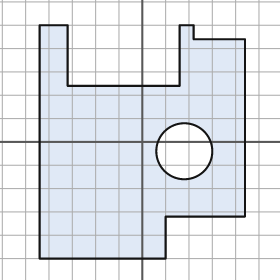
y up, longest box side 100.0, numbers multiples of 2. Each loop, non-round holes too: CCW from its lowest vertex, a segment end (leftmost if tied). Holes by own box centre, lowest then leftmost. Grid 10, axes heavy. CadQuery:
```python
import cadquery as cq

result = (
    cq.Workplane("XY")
    .moveTo(-44.0, -50.0)
    .lineTo(10.0, -50.0)
    .lineTo(10.0, -32.0)
    .lineTo(44.0, -32.0)
    .lineTo(44.0, 44.0)
    .lineTo(22.0, 44.0)
    .lineTo(22.0, 50.0)
    .lineTo(16.0, 50.0)
    .lineTo(16.0, 24.0)
    .lineTo(-32.0, 24.0)
    .lineTo(-32.0, 50.0)
    .lineTo(-44.0, 50.0)
    .close()
    .moveTo(18.0, -4.0)
    .circle(12.0)
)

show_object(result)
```